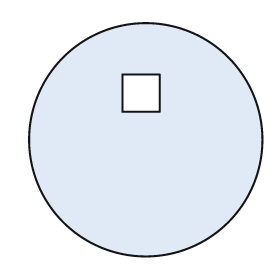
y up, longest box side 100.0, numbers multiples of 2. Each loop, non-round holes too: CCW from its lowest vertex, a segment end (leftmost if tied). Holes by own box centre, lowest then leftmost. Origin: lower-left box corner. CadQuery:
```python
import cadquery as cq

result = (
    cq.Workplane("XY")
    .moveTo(50.0, 50.0)
    .circle(50.0)
    .moveTo(40.0, 62.0)
    .lineTo(56.0, 62.0)
    .lineTo(56.0, 78.0)
    .lineTo(40.0, 78.0)
    .close()
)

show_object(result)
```